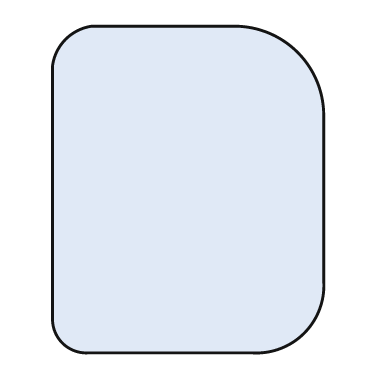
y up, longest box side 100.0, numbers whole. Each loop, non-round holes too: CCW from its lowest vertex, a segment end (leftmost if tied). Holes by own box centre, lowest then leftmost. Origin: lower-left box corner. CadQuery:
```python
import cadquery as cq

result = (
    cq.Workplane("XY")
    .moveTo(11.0, 0.0)
    .lineTo(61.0, 0.0)
    .threePointArc((77.0, 6.0), (83.0, 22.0))
    .lineTo(83.0, 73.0)
    .threePointArc((75.0, 92.0), (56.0, 100.0))
    .lineTo(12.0, 100.0)
    .threePointArc((4.0, 96.0), (0.0, 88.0))
    .lineTo(0.0, 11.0)
    .threePointArc((3.0, 3.0), (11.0, 0.0))
    .close()
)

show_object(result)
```